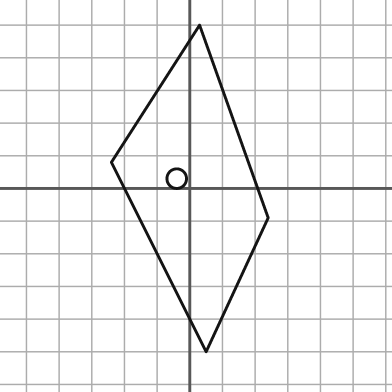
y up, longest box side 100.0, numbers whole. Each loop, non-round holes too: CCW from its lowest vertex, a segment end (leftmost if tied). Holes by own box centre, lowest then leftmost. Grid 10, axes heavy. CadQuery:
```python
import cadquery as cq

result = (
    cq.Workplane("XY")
    .moveTo(5.0, -50.0)
    .lineTo(24.0, -9.0)
    .lineTo(3.0, 50.0)
    .lineTo(-24.0, 8.0)
    .close()
    .moveTo(-4.0, 3.0)
    .circle(3.0)
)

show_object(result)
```